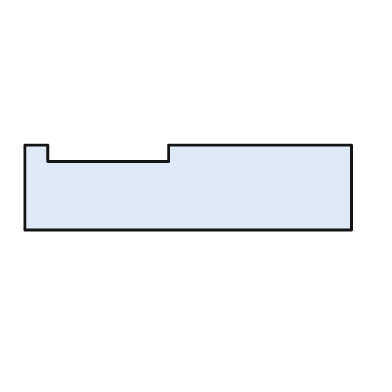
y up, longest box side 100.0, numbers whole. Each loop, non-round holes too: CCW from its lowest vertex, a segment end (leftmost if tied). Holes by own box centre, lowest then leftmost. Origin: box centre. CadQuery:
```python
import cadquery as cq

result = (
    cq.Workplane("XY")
    .moveTo(-50.0, -13.0)
    .lineTo(50.0, -13.0)
    .lineTo(50.0, 13.0)
    .lineTo(-6.0, 13.0)
    .lineTo(-6.0, 8.0)
    .lineTo(-43.0, 8.0)
    .lineTo(-43.0, 13.0)
    .lineTo(-50.0, 13.0)
    .close()
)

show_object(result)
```